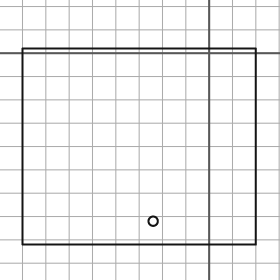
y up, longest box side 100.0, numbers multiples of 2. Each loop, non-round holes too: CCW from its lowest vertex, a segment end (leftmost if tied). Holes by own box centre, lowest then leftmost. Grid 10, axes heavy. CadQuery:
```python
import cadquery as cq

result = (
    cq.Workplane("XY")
    .moveTo(-80.0, -82.0)
    .lineTo(20.0, -82.0)
    .lineTo(20.0, 2.0)
    .lineTo(-80.0, 2.0)
    .close()
    .moveTo(-24.0, -72.0)
    .circle(2.0)
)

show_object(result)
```